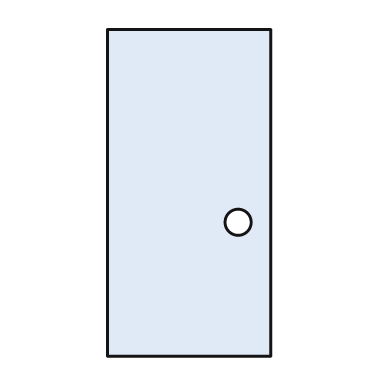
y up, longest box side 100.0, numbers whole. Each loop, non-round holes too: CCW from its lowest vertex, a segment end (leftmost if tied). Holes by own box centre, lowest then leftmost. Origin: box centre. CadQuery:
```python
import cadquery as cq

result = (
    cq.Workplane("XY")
    .moveTo(-25.0, -50.0)
    .lineTo(25.0, -50.0)
    .lineTo(25.0, 50.0)
    .lineTo(-25.0, 50.0)
    .close()
    .moveTo(15.0, -9.0)
    .circle(4.0)
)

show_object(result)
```